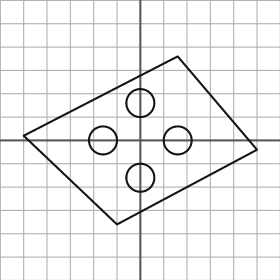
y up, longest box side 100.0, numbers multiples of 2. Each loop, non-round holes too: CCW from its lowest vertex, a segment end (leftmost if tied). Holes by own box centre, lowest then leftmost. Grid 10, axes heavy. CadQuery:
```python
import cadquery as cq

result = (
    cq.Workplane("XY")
    .moveTo(-10.0, -36.0)
    .lineTo(50.0, -4.0)
    .lineTo(16.0, 36.0)
    .lineTo(-50.0, 2.0)
    .close()
    .moveTo(0.0, -16.0)
    .circle(6.0)
    .moveTo(-16.0, 0.0)
    .circle(6.0)
    .moveTo(16.0, 0.0)
    .circle(6.0)
    .moveTo(0.0, 16.0)
    .circle(6.0)
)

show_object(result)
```